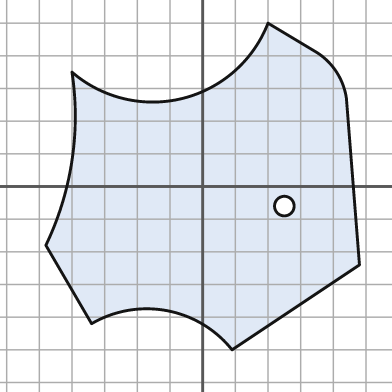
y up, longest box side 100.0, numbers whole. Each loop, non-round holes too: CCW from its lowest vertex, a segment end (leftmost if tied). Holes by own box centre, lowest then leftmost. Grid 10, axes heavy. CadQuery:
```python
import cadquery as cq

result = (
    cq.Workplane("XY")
    .moveTo(9.0, -50.0)
    .lineTo(48.0, -24.0)
    .lineTo(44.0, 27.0)
    .threePointArc((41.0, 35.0), (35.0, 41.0))
    .lineTo(20.0, 50.0)
    .threePointArc((-6.0, 27.0), (-40.0, 35.0))
    .threePointArc((-40.0, 8.0), (-48.0, -18.0))
    .lineTo(-34.0, -42.0)
    .threePointArc((-11.0, -38.0), (9.0, -50.0))
    .close()
    .moveTo(25.0, -6.0)
    .circle(3.0)
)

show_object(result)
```